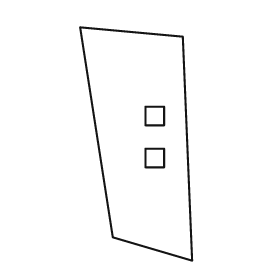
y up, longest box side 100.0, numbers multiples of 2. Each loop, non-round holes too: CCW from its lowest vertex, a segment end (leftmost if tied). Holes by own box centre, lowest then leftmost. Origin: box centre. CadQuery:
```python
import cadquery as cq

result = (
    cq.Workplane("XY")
    .moveTo(24.0, -50.0)
    .lineTo(20.0, 46.0)
    .lineTo(-24.0, 50.0)
    .lineTo(-10.0, -40.0)
    .close()
    .moveTo(4.0, -10.0)
    .lineTo(12.0, -10.0)
    .lineTo(12.0, -2.0)
    .lineTo(4.0, -2.0)
    .close()
    .moveTo(4.0, 8.0)
    .lineTo(12.0, 8.0)
    .lineTo(12.0, 16.0)
    .lineTo(4.0, 16.0)
    .close()
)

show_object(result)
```